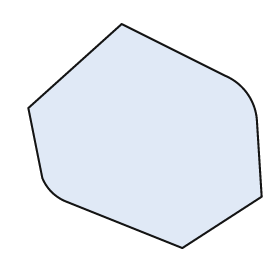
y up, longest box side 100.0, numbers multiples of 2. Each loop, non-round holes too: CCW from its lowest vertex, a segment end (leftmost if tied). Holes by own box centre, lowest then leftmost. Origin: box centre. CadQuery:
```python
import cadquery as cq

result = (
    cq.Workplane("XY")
    .moveTo(16.0, -48.0)
    .lineTo(50.0, -26.0)
    .lineTo(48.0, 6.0)
    .threePointArc((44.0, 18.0), (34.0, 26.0))
    .lineTo(-10.0, 48.0)
    .lineTo(-50.0, 12.0)
    .lineTo(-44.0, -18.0)
    .threePointArc((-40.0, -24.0), (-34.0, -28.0))
    .close()
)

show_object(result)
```